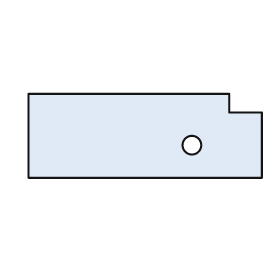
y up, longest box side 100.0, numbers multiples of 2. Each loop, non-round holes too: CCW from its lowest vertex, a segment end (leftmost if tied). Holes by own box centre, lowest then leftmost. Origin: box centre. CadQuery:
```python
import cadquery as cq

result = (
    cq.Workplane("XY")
    .moveTo(-50.0, -18.0)
    .lineTo(50.0, -18.0)
    .lineTo(50.0, 10.0)
    .lineTo(36.0, 10.0)
    .lineTo(36.0, 18.0)
    .lineTo(-50.0, 18.0)
    .close()
    .moveTo(20.0, -4.0)
    .circle(4.0)
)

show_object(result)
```